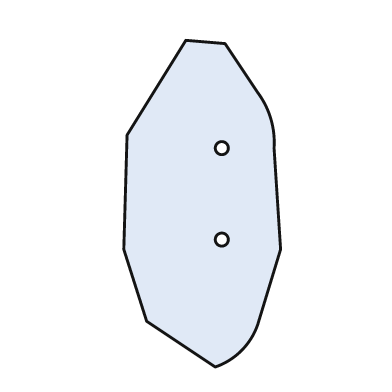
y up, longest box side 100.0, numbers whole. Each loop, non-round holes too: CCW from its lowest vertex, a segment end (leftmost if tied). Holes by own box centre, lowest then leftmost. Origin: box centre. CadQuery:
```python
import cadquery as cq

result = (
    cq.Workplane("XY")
    .moveTo(4.0, -50.0)
    .threePointArc((12.0, -45.0), (17.0, -37.0))
    .lineTo(24.0, -14.0)
    .lineTo(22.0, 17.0)
    .threePointArc((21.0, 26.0), (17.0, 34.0))
    .lineTo(7.0, 49.0)
    .lineTo(-5.0, 50.0)
    .lineTo(-23.0, 21.0)
    .lineTo(-24.0, -14.0)
    .lineTo(-17.0, -36.0)
    .close()
    .moveTo(6.0, -11.0)
    .circle(2.0)
    .moveTo(6.0, 17.0)
    .circle(2.0)
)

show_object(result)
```